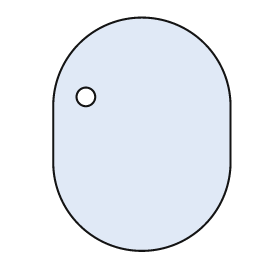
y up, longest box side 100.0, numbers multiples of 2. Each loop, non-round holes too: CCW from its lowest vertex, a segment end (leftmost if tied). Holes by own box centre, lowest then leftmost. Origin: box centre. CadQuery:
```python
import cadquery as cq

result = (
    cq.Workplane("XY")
    .moveTo(-38.0, -12.0)
    .threePointArc((0.0, -50.0), (38.0, -12.0))
    .lineTo(38.0, 12.0)
    .threePointArc((0.0, 50.0), (-38.0, 12.0))
    .close()
    .moveTo(-24.0, 16.0)
    .circle(4.0)
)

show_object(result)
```